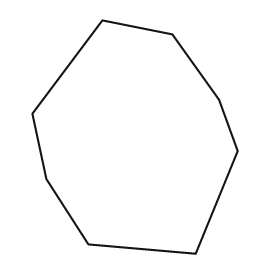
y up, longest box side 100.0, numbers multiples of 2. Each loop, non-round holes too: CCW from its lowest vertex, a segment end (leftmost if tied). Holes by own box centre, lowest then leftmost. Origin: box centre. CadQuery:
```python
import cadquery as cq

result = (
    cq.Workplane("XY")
    .moveTo(26.0, -50.0)
    .lineTo(44.0, -6.0)
    .lineTo(36.0, 16.0)
    .lineTo(16.0, 44.0)
    .lineTo(-14.0, 50.0)
    .lineTo(-44.0, 10.0)
    .lineTo(-38.0, -18.0)
    .lineTo(-20.0, -46.0)
    .close()
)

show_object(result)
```